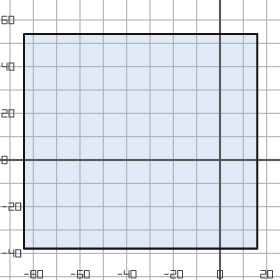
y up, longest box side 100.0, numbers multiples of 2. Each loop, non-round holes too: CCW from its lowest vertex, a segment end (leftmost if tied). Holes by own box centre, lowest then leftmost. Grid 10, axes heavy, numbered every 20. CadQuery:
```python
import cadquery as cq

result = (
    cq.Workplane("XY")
    .moveTo(-84.0, -38.0)
    .lineTo(16.0, -38.0)
    .lineTo(16.0, 54.0)
    .lineTo(-84.0, 54.0)
    .close()
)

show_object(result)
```